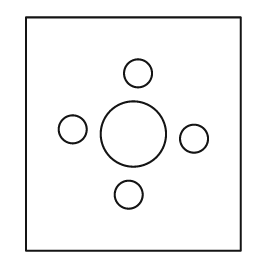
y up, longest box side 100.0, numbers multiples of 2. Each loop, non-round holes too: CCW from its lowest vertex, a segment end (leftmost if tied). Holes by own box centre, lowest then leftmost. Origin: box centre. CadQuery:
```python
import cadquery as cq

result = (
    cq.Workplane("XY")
    .moveTo(-46.0, -50.0)
    .lineTo(46.0, -50.0)
    .lineTo(46.0, 50.0)
    .lineTo(-46.0, 50.0)
    .close()
    .moveTo(-2.0, -26.0)
    .circle(6.0)
    .moveTo(26.0, -2.0)
    .circle(6.0)
    .moveTo(0.0, 0.0)
    .circle(14.0)
    .moveTo(-26.0, 2.0)
    .circle(6.0)
    .moveTo(2.0, 26.0)
    .circle(6.0)
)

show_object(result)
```